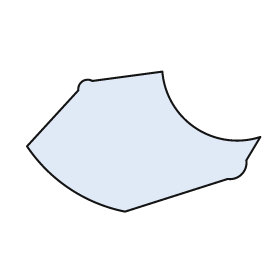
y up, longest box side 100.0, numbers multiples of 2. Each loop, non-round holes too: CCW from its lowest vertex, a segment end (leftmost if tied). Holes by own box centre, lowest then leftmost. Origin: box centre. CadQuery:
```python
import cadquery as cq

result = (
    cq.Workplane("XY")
    .moveTo(-8.0, -30.0)
    .lineTo(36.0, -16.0)
    .threePointArc((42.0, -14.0), (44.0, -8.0))
    .lineTo(50.0, 2.0)
    .threePointArc((22.0, 6.0), (8.0, 30.0))
    .lineTo(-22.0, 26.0)
    .threePointArc((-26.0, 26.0), (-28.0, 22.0))
    .lineTo(-50.0, -2.0)
    .threePointArc((-32.0, -20.0), (-8.0, -30.0))
    .close()
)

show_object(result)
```